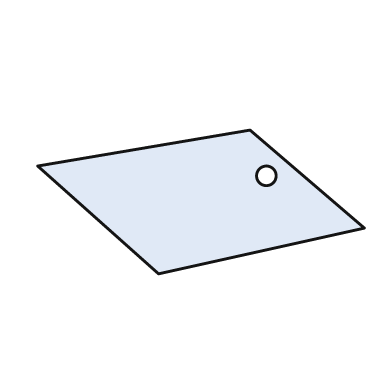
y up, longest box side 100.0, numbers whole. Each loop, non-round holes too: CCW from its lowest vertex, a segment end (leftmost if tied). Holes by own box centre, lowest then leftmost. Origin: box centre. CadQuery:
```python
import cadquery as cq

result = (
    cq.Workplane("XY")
    .moveTo(-13.0, -22.0)
    .lineTo(50.0, -8.0)
    .lineTo(15.0, 22.0)
    .lineTo(-50.0, 11.0)
    .close()
    .moveTo(20.0, 8.0)
    .circle(3.0)
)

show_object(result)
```